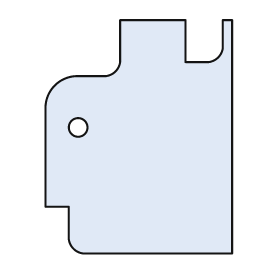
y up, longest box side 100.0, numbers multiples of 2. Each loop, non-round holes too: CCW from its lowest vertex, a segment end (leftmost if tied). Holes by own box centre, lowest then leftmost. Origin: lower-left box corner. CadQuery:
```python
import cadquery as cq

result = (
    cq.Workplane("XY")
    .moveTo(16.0, 0.0)
    .lineTo(80.0, 0.0)
    .lineTo(80.0, 100.0)
    .lineTo(76.0, 100.0)
    .lineTo(76.0, 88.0)
    .threePointArc((74.0, 84.0), (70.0, 82.0))
    .lineTo(60.0, 82.0)
    .lineTo(60.0, 100.0)
    .lineTo(32.0, 100.0)
    .lineTo(32.0, 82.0)
    .threePointArc((30.0, 78.0), (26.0, 76.0))
    .lineTo(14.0, 76.0)
    .threePointArc((4.0, 72.0), (0.0, 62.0))
    .lineTo(0.0, 20.0)
    .lineTo(10.0, 20.0)
    .lineTo(10.0, 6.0)
    .threePointArc((12.0, 2.0), (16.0, 0.0))
    .close()
    .moveTo(14.0, 54.0)
    .circle(4.0)
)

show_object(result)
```